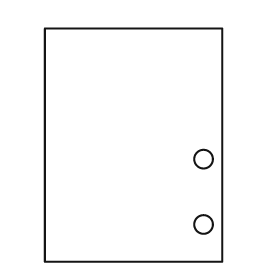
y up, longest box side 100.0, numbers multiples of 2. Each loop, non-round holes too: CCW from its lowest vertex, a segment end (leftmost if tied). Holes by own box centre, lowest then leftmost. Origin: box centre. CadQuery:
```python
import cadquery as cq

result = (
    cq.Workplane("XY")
    .moveTo(-38.0, -50.0)
    .lineTo(38.0, -50.0)
    .lineTo(38.0, 50.0)
    .lineTo(-38.0, 50.0)
    .close()
    .moveTo(30.0, -34.0)
    .circle(4.0)
    .moveTo(30.0, -6.0)
    .circle(4.0)
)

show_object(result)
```